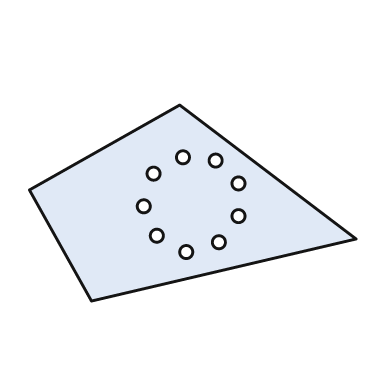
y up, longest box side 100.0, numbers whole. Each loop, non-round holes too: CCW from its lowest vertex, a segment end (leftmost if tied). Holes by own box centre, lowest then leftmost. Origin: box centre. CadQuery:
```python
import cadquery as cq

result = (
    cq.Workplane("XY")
    .moveTo(-31.0, -30.0)
    .lineTo(50.0, -11.0)
    .lineTo(-4.0, 30.0)
    .lineTo(-50.0, 4.0)
    .close()
    .moveTo(-2.0, -15.0)
    .circle(2.0)
    .moveTo(8.0, -12.0)
    .circle(2.0)
    .moveTo(-11.0, -10.0)
    .circle(2.0)
    .moveTo(14.0, -4.0)
    .circle(2.0)
    .moveTo(-15.0, -1.0)
    .circle(2.0)
    .moveTo(14.0, 6.0)
    .circle(2.0)
    .moveTo(-12.0, 9.0)
    .circle(2.0)
    .moveTo(7.0, 13.0)
    .circle(2.0)
    .moveTo(-3.0, 14.0)
    .circle(2.0)
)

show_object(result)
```